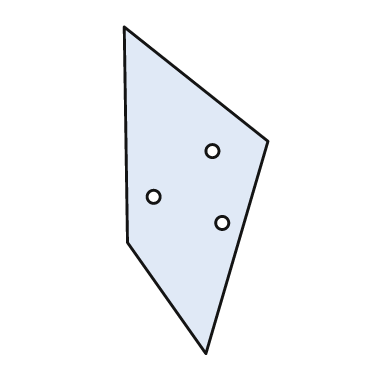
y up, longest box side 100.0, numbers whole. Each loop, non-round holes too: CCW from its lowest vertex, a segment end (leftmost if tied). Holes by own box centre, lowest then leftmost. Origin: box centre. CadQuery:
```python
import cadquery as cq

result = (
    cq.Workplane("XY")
    .moveTo(3.0, -50.0)
    .lineTo(22.0, 15.0)
    .lineTo(-22.0, 50.0)
    .lineTo(-21.0, -16.0)
    .close()
    .moveTo(8.0, -10.0)
    .circle(2.0)
    .moveTo(-13.0, -2.0)
    .circle(2.0)
    .moveTo(5.0, 12.0)
    .circle(2.0)
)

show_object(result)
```